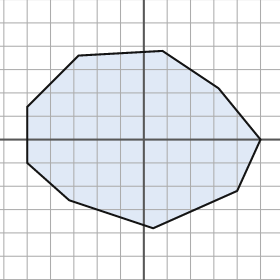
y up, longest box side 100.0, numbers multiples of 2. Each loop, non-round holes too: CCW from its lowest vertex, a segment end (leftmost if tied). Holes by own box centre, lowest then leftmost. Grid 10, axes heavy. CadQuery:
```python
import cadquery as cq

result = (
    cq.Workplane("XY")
    .moveTo(4.0, -38.0)
    .lineTo(40.0, -22.0)
    .lineTo(50.0, 0.0)
    .lineTo(32.0, 22.0)
    .lineTo(8.0, 38.0)
    .lineTo(-28.0, 36.0)
    .lineTo(-50.0, 14.0)
    .lineTo(-50.0, -10.0)
    .lineTo(-32.0, -26.0)
    .close()
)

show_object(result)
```